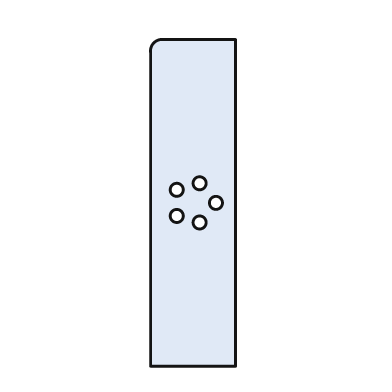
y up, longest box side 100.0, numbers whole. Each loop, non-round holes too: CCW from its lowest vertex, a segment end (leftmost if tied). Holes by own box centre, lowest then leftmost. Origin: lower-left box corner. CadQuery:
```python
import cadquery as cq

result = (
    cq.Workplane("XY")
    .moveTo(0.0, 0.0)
    .lineTo(26.0, 0.0)
    .lineTo(26.0, 100.0)
    .lineTo(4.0, 100.0)
    .threePointArc((1.0, 99.0), (0.0, 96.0))
    .close()
    .moveTo(15.0, 44.0)
    .circle(2.0)
    .moveTo(8.0, 46.0)
    .circle(2.0)
    .moveTo(20.0, 50.0)
    .circle(2.0)
    .moveTo(8.0, 54.0)
    .circle(2.0)
    .moveTo(15.0, 56.0)
    .circle(2.0)
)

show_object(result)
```